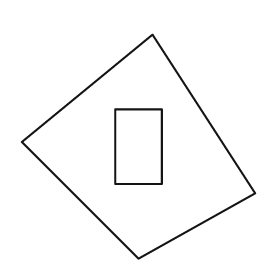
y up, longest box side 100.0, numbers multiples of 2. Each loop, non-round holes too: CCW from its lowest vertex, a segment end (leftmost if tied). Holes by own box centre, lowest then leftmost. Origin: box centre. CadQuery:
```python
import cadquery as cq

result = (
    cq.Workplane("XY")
    .moveTo(0.0, -48.0)
    .lineTo(50.0, -20.0)
    .lineTo(6.0, 48.0)
    .lineTo(-50.0, 2.0)
    .close()
    .moveTo(-10.0, -16.0)
    .lineTo(10.0, -16.0)
    .lineTo(10.0, 16.0)
    .lineTo(-10.0, 16.0)
    .close()
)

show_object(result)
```